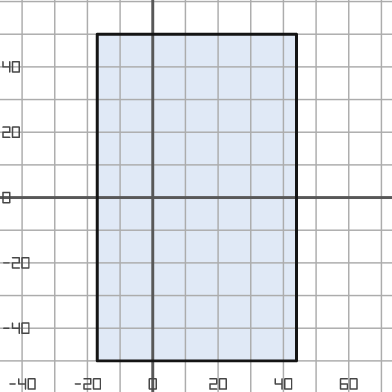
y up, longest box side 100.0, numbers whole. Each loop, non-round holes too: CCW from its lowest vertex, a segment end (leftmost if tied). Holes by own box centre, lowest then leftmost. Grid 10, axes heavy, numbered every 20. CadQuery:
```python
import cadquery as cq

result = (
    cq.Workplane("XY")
    .moveTo(-17.0, -50.0)
    .lineTo(44.0, -50.0)
    .lineTo(44.0, 50.0)
    .lineTo(-17.0, 50.0)
    .close()
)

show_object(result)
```